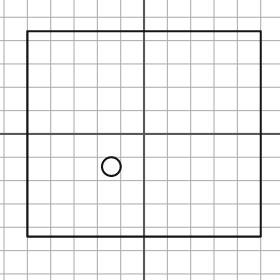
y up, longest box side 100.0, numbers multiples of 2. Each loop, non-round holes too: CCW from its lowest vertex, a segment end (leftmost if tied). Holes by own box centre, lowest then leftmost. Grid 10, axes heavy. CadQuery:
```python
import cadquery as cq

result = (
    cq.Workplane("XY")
    .moveTo(-50.0, -44.0)
    .lineTo(50.0, -44.0)
    .lineTo(50.0, 44.0)
    .lineTo(-50.0, 44.0)
    .close()
    .moveTo(-14.0, -14.0)
    .circle(4.0)
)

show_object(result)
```